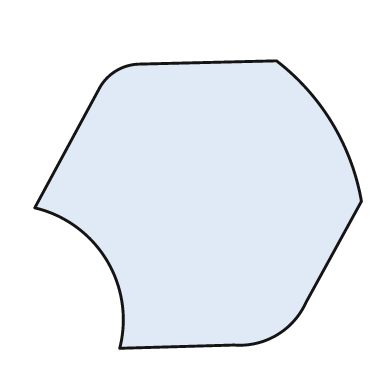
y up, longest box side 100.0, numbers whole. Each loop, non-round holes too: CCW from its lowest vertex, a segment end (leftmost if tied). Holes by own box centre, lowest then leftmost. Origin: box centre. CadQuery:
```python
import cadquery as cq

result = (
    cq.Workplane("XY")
    .moveTo(-24.0, -44.0)
    .lineTo(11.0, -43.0)
    .threePointArc((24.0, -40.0), (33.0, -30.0))
    .lineTo(50.0, 1.0)
    .threePointArc((41.0, 25.0), (24.0, 44.0))
    .lineTo(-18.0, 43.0)
    .threePointArc((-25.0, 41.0), (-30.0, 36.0))
    .lineTo(-50.0, -1.0)
    .threePointArc((-28.0, -17.0), (-24.0, -44.0))
    .close()
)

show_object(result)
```